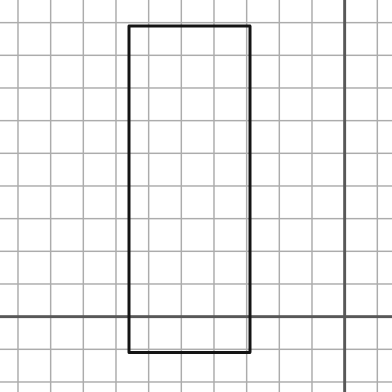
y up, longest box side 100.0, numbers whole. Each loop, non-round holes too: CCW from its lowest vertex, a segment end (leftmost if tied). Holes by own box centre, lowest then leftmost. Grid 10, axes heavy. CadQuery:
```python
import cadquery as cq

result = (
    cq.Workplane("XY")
    .moveTo(-66.0, -11.0)
    .lineTo(-29.0, -11.0)
    .lineTo(-29.0, 89.0)
    .lineTo(-66.0, 89.0)
    .close()
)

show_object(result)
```